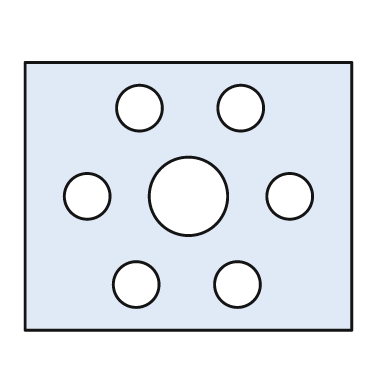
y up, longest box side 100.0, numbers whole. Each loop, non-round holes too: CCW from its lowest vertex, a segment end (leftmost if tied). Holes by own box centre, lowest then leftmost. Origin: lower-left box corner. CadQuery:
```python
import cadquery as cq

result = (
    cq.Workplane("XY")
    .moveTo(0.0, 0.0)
    .lineTo(100.0, 0.0)
    .lineTo(100.0, 82.0)
    .lineTo(0.0, 82.0)
    .close()
    .moveTo(34.0, 14.0)
    .circle(7.0)
    .moveTo(65.0, 14.0)
    .circle(7.0)
    .moveTo(19.0, 41.0)
    .circle(7.0)
    .moveTo(50.0, 41.0)
    .circle(12.0)
    .moveTo(81.0, 41.0)
    .circle(7.0)
    .moveTo(35.0, 68.0)
    .circle(7.0)
    .moveTo(66.0, 68.0)
    .circle(7.0)
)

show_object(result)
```